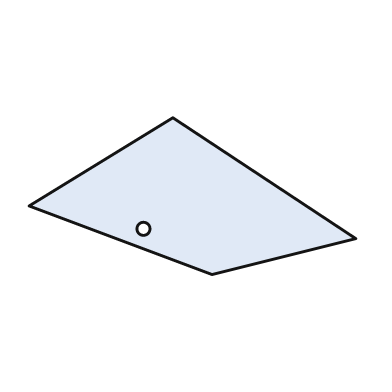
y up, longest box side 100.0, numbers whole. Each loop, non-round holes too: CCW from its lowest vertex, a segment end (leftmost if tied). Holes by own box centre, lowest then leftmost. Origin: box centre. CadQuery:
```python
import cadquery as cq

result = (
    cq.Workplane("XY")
    .moveTo(6.0, -24.0)
    .lineTo(50.0, -13.0)
    .lineTo(-6.0, 24.0)
    .lineTo(-50.0, -3.0)
    .close()
    .moveTo(-15.0, -10.0)
    .circle(2.0)
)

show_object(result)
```